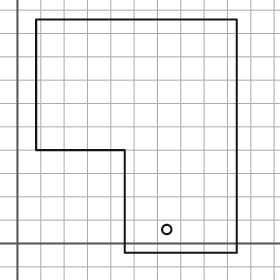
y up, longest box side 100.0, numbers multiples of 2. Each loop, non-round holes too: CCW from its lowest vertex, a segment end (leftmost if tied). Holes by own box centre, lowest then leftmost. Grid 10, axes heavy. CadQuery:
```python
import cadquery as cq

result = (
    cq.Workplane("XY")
    .moveTo(46.0, -4.0)
    .lineTo(94.0, -4.0)
    .lineTo(94.0, 96.0)
    .lineTo(8.0, 96.0)
    .lineTo(8.0, 40.0)
    .lineTo(46.0, 40.0)
    .close()
    .moveTo(64.0, 6.0)
    .circle(2.0)
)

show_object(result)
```